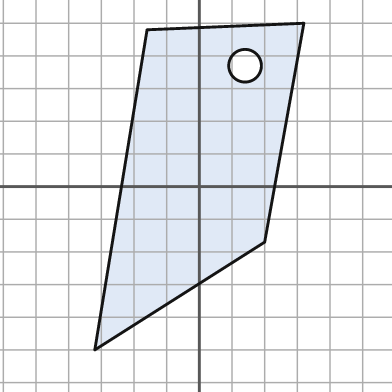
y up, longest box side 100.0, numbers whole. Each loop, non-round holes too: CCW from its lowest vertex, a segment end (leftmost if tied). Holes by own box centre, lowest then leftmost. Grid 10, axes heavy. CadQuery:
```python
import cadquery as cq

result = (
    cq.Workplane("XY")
    .moveTo(-32.0, -50.0)
    .lineTo(20.0, -17.0)
    .lineTo(32.0, 50.0)
    .lineTo(-16.0, 48.0)
    .close()
    .moveTo(14.0, 37.0)
    .circle(5.0)
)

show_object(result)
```